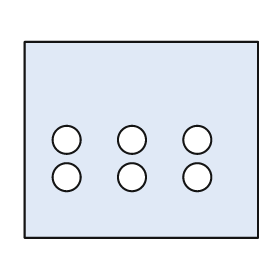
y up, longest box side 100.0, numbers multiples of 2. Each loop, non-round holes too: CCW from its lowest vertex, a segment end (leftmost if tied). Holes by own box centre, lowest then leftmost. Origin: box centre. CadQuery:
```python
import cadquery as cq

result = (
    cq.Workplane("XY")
    .moveTo(-50.0, -42.0)
    .lineTo(50.0, -42.0)
    .lineTo(50.0, 42.0)
    .lineTo(-50.0, 42.0)
    .close()
    .moveTo(-32.0, -16.0)
    .circle(6.0)
    .moveTo(-4.0, -16.0)
    .circle(6.0)
    .moveTo(24.0, -16.0)
    .circle(6.0)
    .moveTo(-32.0, 0.0)
    .circle(6.0)
    .moveTo(-4.0, 0.0)
    .circle(6.0)
    .moveTo(24.0, 0.0)
    .circle(6.0)
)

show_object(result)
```